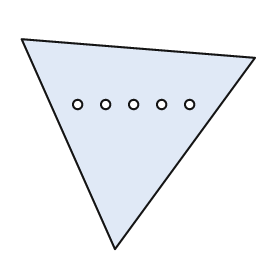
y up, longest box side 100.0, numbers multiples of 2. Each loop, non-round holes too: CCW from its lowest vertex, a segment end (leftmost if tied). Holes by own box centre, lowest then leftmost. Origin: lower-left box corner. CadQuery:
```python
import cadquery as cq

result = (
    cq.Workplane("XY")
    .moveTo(40.0, 0.0)
    .lineTo(100.0, 82.0)
    .lineTo(0.0, 90.0)
    .close()
    .moveTo(24.0, 62.0)
    .circle(2.0)
    .moveTo(36.0, 62.0)
    .circle(2.0)
    .moveTo(48.0, 62.0)
    .circle(2.0)
    .moveTo(60.0, 62.0)
    .circle(2.0)
    .moveTo(72.0, 62.0)
    .circle(2.0)
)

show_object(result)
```